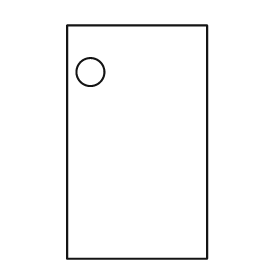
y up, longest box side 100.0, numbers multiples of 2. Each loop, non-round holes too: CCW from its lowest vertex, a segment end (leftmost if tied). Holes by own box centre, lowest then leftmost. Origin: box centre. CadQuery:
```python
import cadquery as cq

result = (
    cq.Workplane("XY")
    .moveTo(-30.0, -50.0)
    .lineTo(30.0, -50.0)
    .lineTo(30.0, 50.0)
    .lineTo(-30.0, 50.0)
    .close()
    .moveTo(-20.0, 30.0)
    .circle(6.0)
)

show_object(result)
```